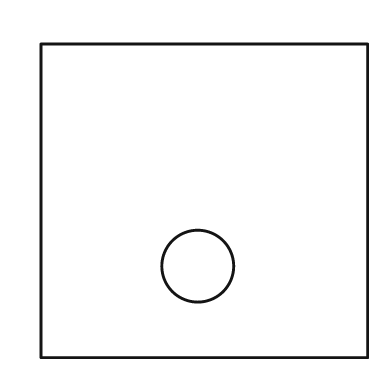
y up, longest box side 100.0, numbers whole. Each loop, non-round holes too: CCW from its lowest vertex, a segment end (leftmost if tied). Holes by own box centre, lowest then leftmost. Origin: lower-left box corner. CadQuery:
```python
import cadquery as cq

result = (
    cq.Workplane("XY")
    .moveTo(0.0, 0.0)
    .lineTo(100.0, 0.0)
    .lineTo(100.0, 96.0)
    .lineTo(0.0, 96.0)
    .close()
    .moveTo(48.0, 28.0)
    .circle(11.0)
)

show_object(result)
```